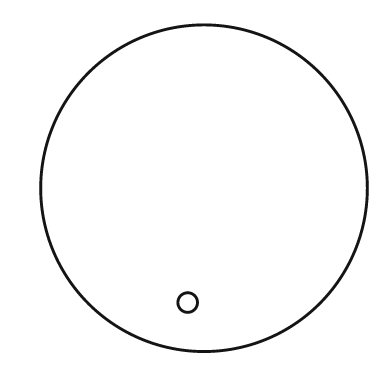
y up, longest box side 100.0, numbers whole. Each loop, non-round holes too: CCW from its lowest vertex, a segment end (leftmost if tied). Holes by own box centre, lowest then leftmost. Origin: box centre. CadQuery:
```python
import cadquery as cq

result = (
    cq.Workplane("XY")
    .moveTo(0.0, 0.0)
    .circle(50.0)
    .moveTo(-5.0, -35.0)
    .circle(3.0)
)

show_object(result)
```